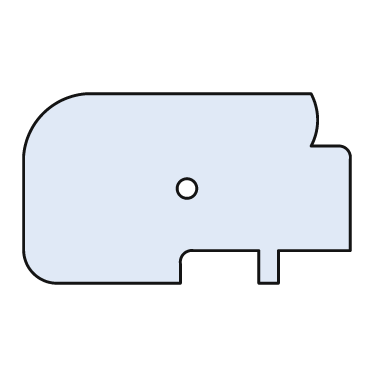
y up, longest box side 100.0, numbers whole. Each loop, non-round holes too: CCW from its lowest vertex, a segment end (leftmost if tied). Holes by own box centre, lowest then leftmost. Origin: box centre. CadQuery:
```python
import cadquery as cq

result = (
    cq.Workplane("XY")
    .moveTo(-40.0, -29.0)
    .lineTo(-2.0, -29.0)
    .lineTo(-2.0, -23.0)
    .threePointArc((-1.0, -20.0), (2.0, -19.0))
    .lineTo(22.0, -19.0)
    .lineTo(22.0, -29.0)
    .lineTo(28.0, -29.0)
    .lineTo(28.0, -19.0)
    .lineTo(50.0, -19.0)
    .lineTo(50.0, 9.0)
    .threePointArc((49.0, 12.0), (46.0, 13.0))
    .lineTo(38.0, 13.0)
    .threePointArc((40.0, 21.0), (38.0, 29.0))
    .lineTo(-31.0, 29.0)
    .threePointArc((-44.0, 23.0), (-50.0, 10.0))
    .lineTo(-50.0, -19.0)
    .threePointArc((-47.0, -26.0), (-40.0, -29.0))
    .close()
    .moveTo(0.0, 0.0)
    .circle(3.0)
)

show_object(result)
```